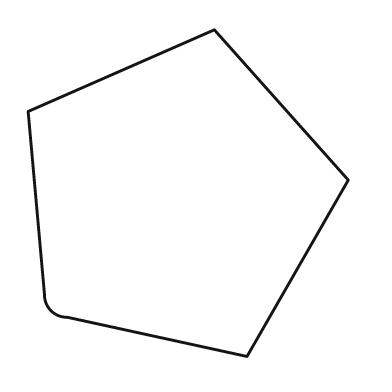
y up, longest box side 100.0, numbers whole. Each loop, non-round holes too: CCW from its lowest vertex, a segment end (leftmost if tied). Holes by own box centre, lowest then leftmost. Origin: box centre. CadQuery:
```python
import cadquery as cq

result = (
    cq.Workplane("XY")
    .moveTo(18.0, -50.0)
    .lineTo(49.0, 4.0)
    .lineTo(8.0, 50.0)
    .lineTo(-49.0, 25.0)
    .lineTo(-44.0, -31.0)
    .threePointArc((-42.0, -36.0), (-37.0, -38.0))
    .close()
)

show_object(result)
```